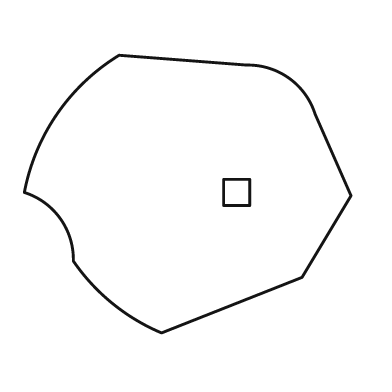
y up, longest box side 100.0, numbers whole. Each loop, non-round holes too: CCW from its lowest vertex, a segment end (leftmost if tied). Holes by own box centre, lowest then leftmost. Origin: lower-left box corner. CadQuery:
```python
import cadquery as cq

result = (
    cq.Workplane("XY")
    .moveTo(42.0, 0.0)
    .lineTo(85.0, 17.0)
    .lineTo(100.0, 42.0)
    .lineTo(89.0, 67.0)
    .threePointArc((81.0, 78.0), (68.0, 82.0))
    .lineTo(29.0, 85.0)
    .threePointArc((10.0, 67.0), (0.0, 43.0))
    .threePointArc((11.0, 35.0), (15.0, 22.0))
    .threePointArc((27.0, 9.0), (42.0, 0.0))
    .close()
    .moveTo(61.0, 39.0)
    .lineTo(69.0, 39.0)
    .lineTo(69.0, 47.0)
    .lineTo(61.0, 47.0)
    .close()
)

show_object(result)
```